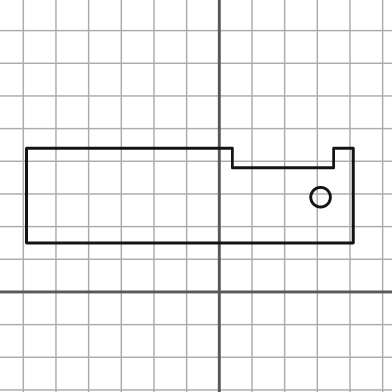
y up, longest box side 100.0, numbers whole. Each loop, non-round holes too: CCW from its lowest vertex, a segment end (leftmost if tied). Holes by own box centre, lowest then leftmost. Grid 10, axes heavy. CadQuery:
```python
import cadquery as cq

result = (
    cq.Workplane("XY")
    .moveTo(-59.0, 15.0)
    .lineTo(41.0, 15.0)
    .lineTo(41.0, 44.0)
    .lineTo(35.0, 44.0)
    .lineTo(35.0, 38.0)
    .lineTo(4.0, 38.0)
    .lineTo(4.0, 44.0)
    .lineTo(-59.0, 44.0)
    .close()
    .moveTo(31.0, 29.0)
    .circle(3.0)
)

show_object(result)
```